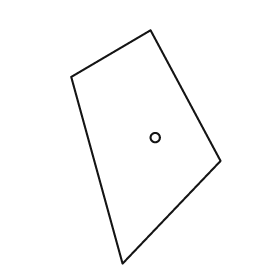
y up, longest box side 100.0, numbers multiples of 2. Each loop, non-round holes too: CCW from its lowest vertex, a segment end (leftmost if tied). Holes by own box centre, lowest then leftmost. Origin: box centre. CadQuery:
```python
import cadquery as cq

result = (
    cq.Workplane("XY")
    .moveTo(-10.0, -50.0)
    .lineTo(32.0, -6.0)
    .lineTo(2.0, 50.0)
    .lineTo(-32.0, 30.0)
    .close()
    .moveTo(4.0, 4.0)
    .circle(2.0)
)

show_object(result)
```